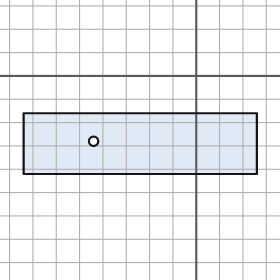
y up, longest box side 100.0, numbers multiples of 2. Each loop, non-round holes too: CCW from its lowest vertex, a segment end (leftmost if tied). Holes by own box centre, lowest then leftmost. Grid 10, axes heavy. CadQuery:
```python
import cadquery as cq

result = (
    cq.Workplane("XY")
    .moveTo(-74.0, -42.0)
    .lineTo(26.0, -42.0)
    .lineTo(26.0, -16.0)
    .lineTo(-74.0, -16.0)
    .close()
    .moveTo(-44.0, -28.0)
    .circle(2.0)
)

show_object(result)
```